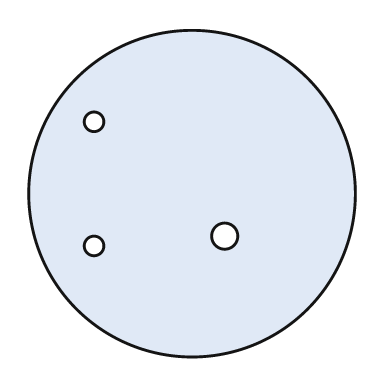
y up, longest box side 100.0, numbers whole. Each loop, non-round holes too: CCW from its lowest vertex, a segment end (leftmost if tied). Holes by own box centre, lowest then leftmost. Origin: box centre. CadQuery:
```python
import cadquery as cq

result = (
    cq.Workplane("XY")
    .moveTo(0.0, 0.0)
    .circle(50.0)
    .moveTo(-30.0, -16.0)
    .circle(3.0)
    .moveTo(10.0, -13.0)
    .circle(4.0)
    .moveTo(-30.0, 22.0)
    .circle(3.0)
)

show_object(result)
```